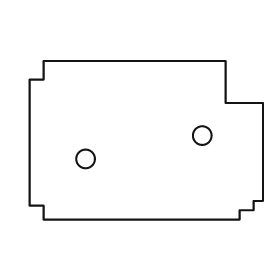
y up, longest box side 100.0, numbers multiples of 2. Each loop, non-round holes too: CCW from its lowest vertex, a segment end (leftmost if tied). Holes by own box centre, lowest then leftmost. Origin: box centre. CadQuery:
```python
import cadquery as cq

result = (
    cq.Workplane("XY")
    .moveTo(-44.0, -34.0)
    .lineTo(40.0, -34.0)
    .lineTo(40.0, -30.0)
    .lineTo(46.0, -30.0)
    .lineTo(46.0, -26.0)
    .lineTo(50.0, -26.0)
    .lineTo(50.0, 16.0)
    .lineTo(34.0, 16.0)
    .lineTo(34.0, 34.0)
    .lineTo(-44.0, 34.0)
    .lineTo(-44.0, 26.0)
    .lineTo(-50.0, 26.0)
    .lineTo(-50.0, -28.0)
    .lineTo(-44.0, -28.0)
    .close()
    .moveTo(-26.0, -8.0)
    .circle(4.0)
    .moveTo(24.0, 2.0)
    .circle(4.0)
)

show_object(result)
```